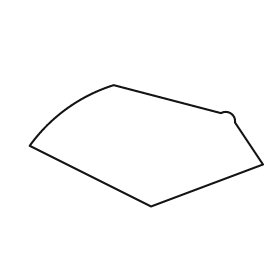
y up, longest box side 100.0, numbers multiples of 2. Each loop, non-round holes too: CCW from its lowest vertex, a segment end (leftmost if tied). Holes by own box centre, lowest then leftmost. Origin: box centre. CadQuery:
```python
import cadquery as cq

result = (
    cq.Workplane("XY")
    .moveTo(2.0, -26.0)
    .lineTo(50.0, -8.0)
    .lineTo(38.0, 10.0)
    .threePointArc((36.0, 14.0), (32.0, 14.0))
    .lineTo(-14.0, 26.0)
    .threePointArc((-34.0, 16.0), (-50.0, 0.0))
    .close()
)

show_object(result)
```